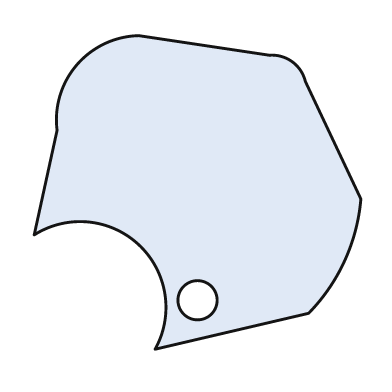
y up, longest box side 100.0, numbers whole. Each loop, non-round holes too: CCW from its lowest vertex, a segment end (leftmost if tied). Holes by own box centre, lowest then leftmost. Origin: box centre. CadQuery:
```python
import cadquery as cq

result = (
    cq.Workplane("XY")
    .moveTo(-13.0, -48.0)
    .lineTo(34.0, -37.0)
    .threePointArc((45.0, -21.0), (50.0, -2.0))
    .lineTo(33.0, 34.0)
    .threePointArc((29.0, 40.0), (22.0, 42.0))
    .lineTo(-18.0, 48.0)
    .threePointArc((-37.0, 39.0), (-43.0, 19.0))
    .lineTo(-50.0, -13.0)
    .threePointArc((-18.0, -16.0), (-13.0, -48.0))
    .close()
    .moveTo(0.0, -33.0)
    .circle(6.0)
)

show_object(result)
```